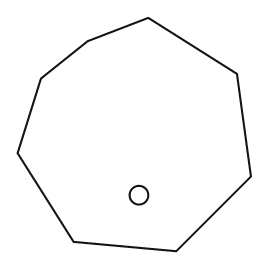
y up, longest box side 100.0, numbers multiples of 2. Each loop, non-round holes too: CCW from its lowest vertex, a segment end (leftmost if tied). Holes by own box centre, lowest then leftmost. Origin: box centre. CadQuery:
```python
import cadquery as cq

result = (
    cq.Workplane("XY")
    .moveTo(18.0, -50.0)
    .lineTo(50.0, -18.0)
    .lineTo(44.0, 26.0)
    .lineTo(6.0, 50.0)
    .lineTo(-20.0, 40.0)
    .lineTo(-40.0, 24.0)
    .lineTo(-50.0, -8.0)
    .lineTo(-26.0, -46.0)
    .close()
    .moveTo(2.0, -26.0)
    .circle(4.0)
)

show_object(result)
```